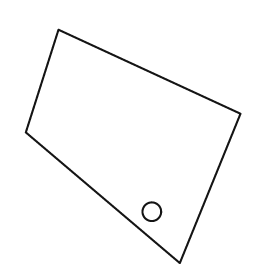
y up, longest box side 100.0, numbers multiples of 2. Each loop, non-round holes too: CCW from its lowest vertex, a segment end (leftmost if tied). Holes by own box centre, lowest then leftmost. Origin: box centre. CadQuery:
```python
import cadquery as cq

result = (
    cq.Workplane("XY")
    .moveTo(20.0, -50.0)
    .lineTo(46.0, 14.0)
    .lineTo(-32.0, 50.0)
    .lineTo(-46.0, 6.0)
    .close()
    .moveTo(8.0, -28.0)
    .circle(4.0)
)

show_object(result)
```